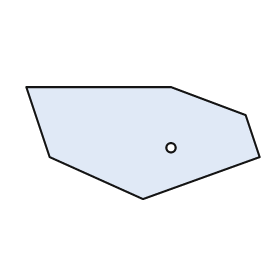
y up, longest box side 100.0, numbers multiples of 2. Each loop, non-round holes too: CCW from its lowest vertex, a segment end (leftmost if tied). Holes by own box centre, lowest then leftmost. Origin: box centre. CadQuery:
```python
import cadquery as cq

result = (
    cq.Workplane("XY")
    .moveTo(0.0, -24.0)
    .lineTo(50.0, -6.0)
    .lineTo(44.0, 12.0)
    .lineTo(12.0, 24.0)
    .lineTo(-50.0, 24.0)
    .lineTo(-40.0, -6.0)
    .close()
    .moveTo(12.0, -2.0)
    .circle(2.0)
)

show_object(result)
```